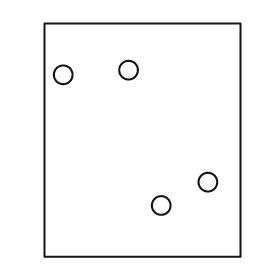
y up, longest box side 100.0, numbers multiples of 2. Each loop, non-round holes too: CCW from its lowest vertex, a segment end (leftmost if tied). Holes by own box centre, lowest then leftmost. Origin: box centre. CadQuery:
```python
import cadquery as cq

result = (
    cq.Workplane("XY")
    .moveTo(-42.0, -50.0)
    .lineTo(42.0, -50.0)
    .lineTo(42.0, 50.0)
    .lineTo(-42.0, 50.0)
    .close()
    .moveTo(8.0, -28.0)
    .circle(4.0)
    .moveTo(28.0, -18.0)
    .circle(4.0)
    .moveTo(-34.0, 28.0)
    .circle(4.0)
    .moveTo(-6.0, 30.0)
    .circle(4.0)
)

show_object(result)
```